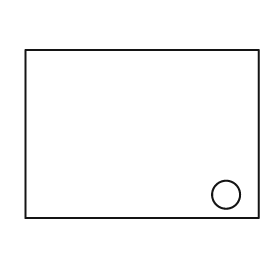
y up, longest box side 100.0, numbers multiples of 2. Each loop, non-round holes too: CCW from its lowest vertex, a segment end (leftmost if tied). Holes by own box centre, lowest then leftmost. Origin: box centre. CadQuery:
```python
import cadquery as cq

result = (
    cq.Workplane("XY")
    .moveTo(-50.0, -36.0)
    .lineTo(50.0, -36.0)
    .lineTo(50.0, 36.0)
    .lineTo(-50.0, 36.0)
    .close()
    .moveTo(36.0, -26.0)
    .circle(6.0)
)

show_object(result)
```